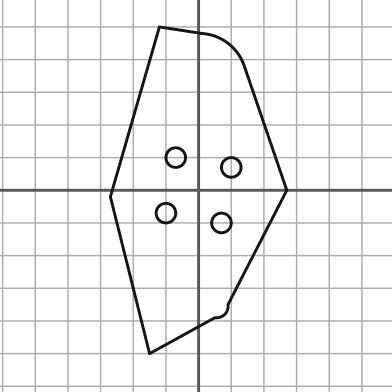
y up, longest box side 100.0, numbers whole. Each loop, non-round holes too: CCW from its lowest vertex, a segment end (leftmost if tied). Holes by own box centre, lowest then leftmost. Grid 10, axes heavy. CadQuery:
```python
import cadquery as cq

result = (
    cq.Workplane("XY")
    .moveTo(-15.0, -50.0)
    .lineTo(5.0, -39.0)
    .threePointArc((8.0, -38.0), (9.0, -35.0))
    .lineTo(27.0, 0.0)
    .lineTo(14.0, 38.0)
    .threePointArc((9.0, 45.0), (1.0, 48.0))
    .lineTo(-12.0, 50.0)
    .lineTo(-27.0, -2.0)
    .close()
    .moveTo(7.0, -10.0)
    .circle(3.0)
    .moveTo(-10.0, -7.0)
    .circle(3.0)
    .moveTo(10.0, 7.0)
    .circle(3.0)
    .moveTo(-7.0, 10.0)
    .circle(3.0)
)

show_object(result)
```